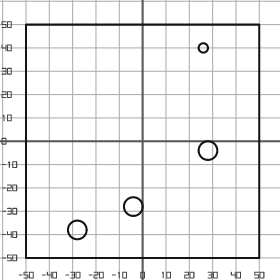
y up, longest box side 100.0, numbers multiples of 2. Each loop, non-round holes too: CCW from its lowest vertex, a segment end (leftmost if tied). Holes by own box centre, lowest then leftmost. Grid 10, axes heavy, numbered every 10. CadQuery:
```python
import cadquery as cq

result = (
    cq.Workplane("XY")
    .moveTo(-50.0, -50.0)
    .lineTo(50.0, -50.0)
    .lineTo(50.0, 50.0)
    .lineTo(-50.0, 50.0)
    .close()
    .moveTo(-28.0, -38.0)
    .circle(4.0)
    .moveTo(-4.0, -28.0)
    .circle(4.0)
    .moveTo(28.0, -4.0)
    .circle(4.0)
    .moveTo(26.0, 40.0)
    .circle(2.0)
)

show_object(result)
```